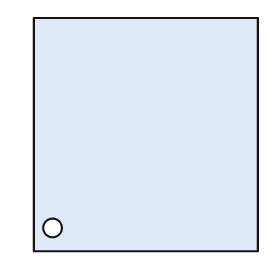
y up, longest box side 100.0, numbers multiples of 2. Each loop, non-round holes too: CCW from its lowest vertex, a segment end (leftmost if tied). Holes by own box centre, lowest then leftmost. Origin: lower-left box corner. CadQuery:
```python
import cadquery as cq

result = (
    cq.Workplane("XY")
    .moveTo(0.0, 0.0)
    .lineTo(96.0, 0.0)
    .lineTo(96.0, 100.0)
    .lineTo(0.0, 100.0)
    .close()
    .moveTo(8.0, 10.0)
    .circle(4.0)
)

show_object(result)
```